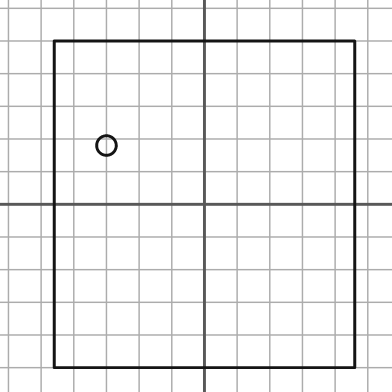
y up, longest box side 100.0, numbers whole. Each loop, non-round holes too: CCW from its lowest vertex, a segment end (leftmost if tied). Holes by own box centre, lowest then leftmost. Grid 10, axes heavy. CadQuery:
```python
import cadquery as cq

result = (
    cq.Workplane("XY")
    .moveTo(-46.0, -50.0)
    .lineTo(46.0, -50.0)
    .lineTo(46.0, 50.0)
    .lineTo(-46.0, 50.0)
    .close()
    .moveTo(-30.0, 18.0)
    .circle(3.0)
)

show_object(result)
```